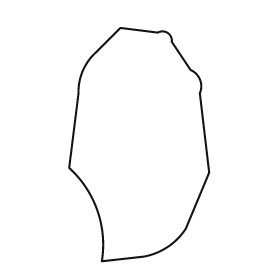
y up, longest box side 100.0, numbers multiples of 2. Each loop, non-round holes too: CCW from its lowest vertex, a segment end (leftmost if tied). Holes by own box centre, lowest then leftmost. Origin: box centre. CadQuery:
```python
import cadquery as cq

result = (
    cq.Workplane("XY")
    .moveTo(-16.0, -50.0)
    .lineTo(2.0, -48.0)
    .threePointArc((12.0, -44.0), (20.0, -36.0))
    .lineTo(30.0, -12.0)
    .lineTo(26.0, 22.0)
    .threePointArc((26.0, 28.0), (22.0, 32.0))
    .lineTo(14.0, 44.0)
    .threePointArc((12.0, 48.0), (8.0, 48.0))
    .lineTo(-8.0, 50.0)
    .lineTo(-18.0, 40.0)
    .threePointArc((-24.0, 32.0), (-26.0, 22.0))
    .lineTo(-30.0, -10.0)
    .threePointArc((-18.0, -28.0), (-16.0, -50.0))
    .close()
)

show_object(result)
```